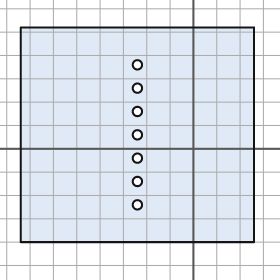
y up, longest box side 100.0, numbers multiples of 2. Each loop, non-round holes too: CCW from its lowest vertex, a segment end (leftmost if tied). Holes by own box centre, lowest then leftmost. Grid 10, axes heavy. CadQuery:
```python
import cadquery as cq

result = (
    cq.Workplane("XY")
    .moveTo(-74.0, -40.0)
    .lineTo(26.0, -40.0)
    .lineTo(26.0, 52.0)
    .lineTo(-74.0, 52.0)
    .close()
    .moveTo(-24.0, -24.0)
    .circle(2.0)
    .moveTo(-24.0, -14.0)
    .circle(2.0)
    .moveTo(-24.0, -4.0)
    .circle(2.0)
    .moveTo(-24.0, 6.0)
    .circle(2.0)
    .moveTo(-24.0, 16.0)
    .circle(2.0)
    .moveTo(-24.0, 26.0)
    .circle(2.0)
    .moveTo(-24.0, 36.0)
    .circle(2.0)
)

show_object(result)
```